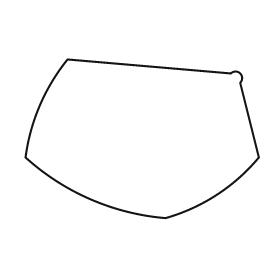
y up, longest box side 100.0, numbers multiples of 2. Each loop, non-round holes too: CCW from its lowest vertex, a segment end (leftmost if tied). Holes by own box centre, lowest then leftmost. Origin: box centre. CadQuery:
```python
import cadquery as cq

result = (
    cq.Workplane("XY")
    .moveTo(10.0, -34.0)
    .threePointArc((32.0, -24.0), (50.0, -8.0))
    .lineTo(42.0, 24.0)
    .threePointArc((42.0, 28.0), (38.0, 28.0))
    .lineTo(-32.0, 34.0)
    .threePointArc((-44.0, 14.0), (-50.0, -8.0))
    .threePointArc((-22.0, -26.0), (10.0, -34.0))
    .close()
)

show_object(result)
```